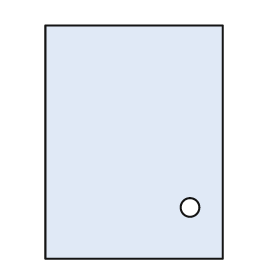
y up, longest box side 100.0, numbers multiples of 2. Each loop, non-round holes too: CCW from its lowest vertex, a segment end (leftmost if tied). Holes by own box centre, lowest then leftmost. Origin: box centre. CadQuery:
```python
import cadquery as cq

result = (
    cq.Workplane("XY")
    .moveTo(-38.0, -50.0)
    .lineTo(38.0, -50.0)
    .lineTo(38.0, 50.0)
    .lineTo(-38.0, 50.0)
    .close()
    .moveTo(24.0, -28.0)
    .circle(4.0)
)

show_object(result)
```